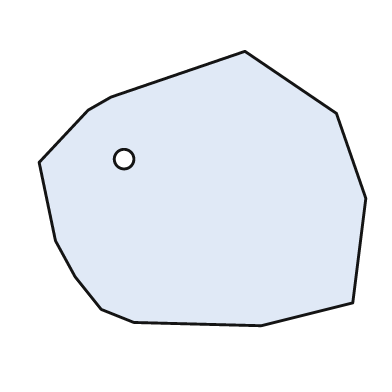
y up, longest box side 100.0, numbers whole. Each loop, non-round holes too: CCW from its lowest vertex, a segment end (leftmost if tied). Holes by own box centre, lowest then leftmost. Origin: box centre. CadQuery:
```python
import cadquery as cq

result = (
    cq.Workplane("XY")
    .moveTo(18.0, -42.0)
    .lineTo(46.0, -35.0)
    .lineTo(50.0, -3.0)
    .lineTo(41.0, 23.0)
    .lineTo(13.0, 42.0)
    .lineTo(-28.0, 28.0)
    .lineTo(-35.0, 24.0)
    .lineTo(-50.0, 8.0)
    .lineTo(-45.0, -16.0)
    .lineTo(-39.0, -27.0)
    .lineTo(-31.0, -37.0)
    .lineTo(-21.0, -41.0)
    .close()
    .moveTo(-24.0, 9.0)
    .circle(3.0)
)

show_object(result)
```